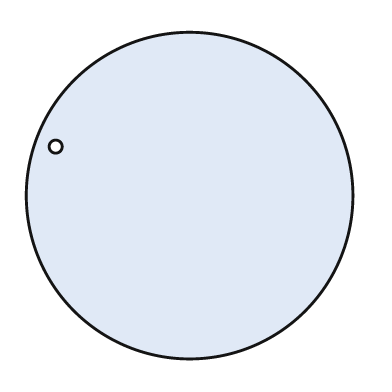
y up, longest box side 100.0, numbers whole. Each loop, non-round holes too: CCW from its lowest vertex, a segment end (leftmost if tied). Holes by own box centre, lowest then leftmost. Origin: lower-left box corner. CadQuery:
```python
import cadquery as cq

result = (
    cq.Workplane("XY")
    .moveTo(50.0, 50.0)
    .circle(50.0)
    .moveTo(9.0, 65.0)
    .circle(2.0)
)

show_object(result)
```